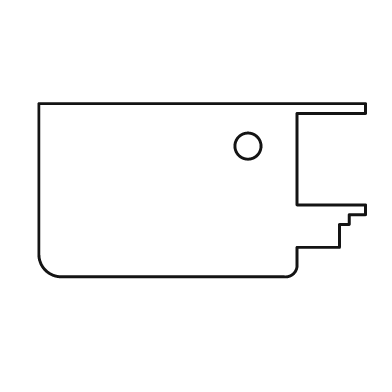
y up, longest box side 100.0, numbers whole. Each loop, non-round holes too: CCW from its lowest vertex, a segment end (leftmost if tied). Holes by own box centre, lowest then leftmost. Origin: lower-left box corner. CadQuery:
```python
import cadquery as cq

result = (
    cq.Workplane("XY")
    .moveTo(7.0, 0.0)
    .lineTo(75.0, 0.0)
    .threePointArc((78.0, 1.0), (79.0, 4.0))
    .lineTo(79.0, 9.0)
    .lineTo(92.0, 9.0)
    .lineTo(92.0, 16.0)
    .lineTo(95.0, 16.0)
    .lineTo(95.0, 19.0)
    .lineTo(100.0, 19.0)
    .lineTo(100.0, 22.0)
    .lineTo(79.0, 22.0)
    .lineTo(79.0, 50.0)
    .lineTo(100.0, 50.0)
    .lineTo(100.0, 53.0)
    .lineTo(0.0, 53.0)
    .lineTo(0.0, 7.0)
    .threePointArc((2.0, 2.0), (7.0, 0.0))
    .close()
    .moveTo(64.0, 40.0)
    .circle(4.0)
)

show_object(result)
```